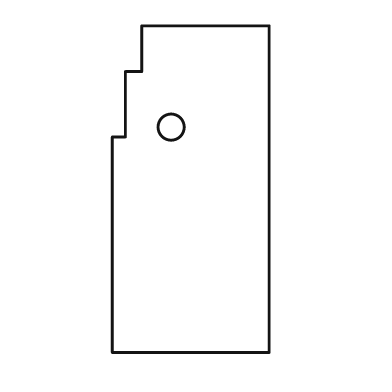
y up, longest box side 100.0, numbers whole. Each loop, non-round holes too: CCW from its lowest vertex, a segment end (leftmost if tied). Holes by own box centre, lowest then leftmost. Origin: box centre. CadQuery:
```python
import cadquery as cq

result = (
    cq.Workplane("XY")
    .moveTo(-24.0, -50.0)
    .lineTo(24.0, -50.0)
    .lineTo(24.0, 50.0)
    .lineTo(-15.0, 50.0)
    .lineTo(-15.0, 36.0)
    .lineTo(-20.0, 36.0)
    .lineTo(-20.0, 16.0)
    .lineTo(-24.0, 16.0)
    .close()
    .moveTo(-6.0, 19.0)
    .circle(4.0)
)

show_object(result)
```